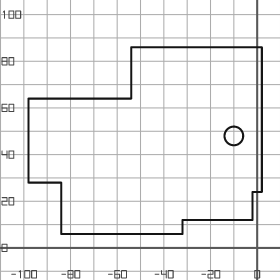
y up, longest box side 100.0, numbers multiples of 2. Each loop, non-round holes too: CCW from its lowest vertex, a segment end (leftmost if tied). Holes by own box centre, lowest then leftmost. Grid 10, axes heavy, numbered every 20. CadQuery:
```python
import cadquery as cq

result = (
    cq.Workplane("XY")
    .moveTo(-84.0, 6.0)
    .lineTo(-32.0, 6.0)
    .lineTo(-32.0, 12.0)
    .lineTo(-2.0, 12.0)
    .lineTo(-2.0, 24.0)
    .lineTo(2.0, 24.0)
    .lineTo(2.0, 86.0)
    .lineTo(-54.0, 86.0)
    .lineTo(-54.0, 64.0)
    .lineTo(-98.0, 64.0)
    .lineTo(-98.0, 28.0)
    .lineTo(-84.0, 28.0)
    .close()
    .moveTo(-10.0, 48.0)
    .circle(4.0)
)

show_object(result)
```